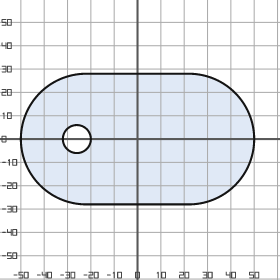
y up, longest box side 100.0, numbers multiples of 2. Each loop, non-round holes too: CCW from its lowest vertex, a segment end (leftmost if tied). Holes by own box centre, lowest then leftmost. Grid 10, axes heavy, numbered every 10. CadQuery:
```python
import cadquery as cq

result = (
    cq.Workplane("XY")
    .moveTo(-22.0, -28.0)
    .lineTo(22.0, -28.0)
    .threePointArc((50.0, 0.0), (22.0, 28.0))
    .lineTo(-22.0, 28.0)
    .threePointArc((-50.0, 0.0), (-22.0, -28.0))
    .close()
    .moveTo(-26.0, 0.0)
    .circle(6.0)
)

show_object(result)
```